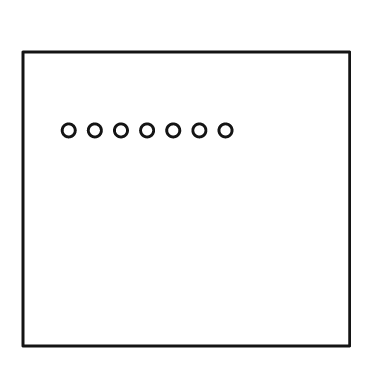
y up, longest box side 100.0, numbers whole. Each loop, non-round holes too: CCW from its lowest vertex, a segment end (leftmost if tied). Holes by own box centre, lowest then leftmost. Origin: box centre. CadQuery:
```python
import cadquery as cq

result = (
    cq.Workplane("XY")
    .moveTo(-50.0, -45.0)
    .lineTo(50.0, -45.0)
    .lineTo(50.0, 45.0)
    .lineTo(-50.0, 45.0)
    .close()
    .moveTo(-36.0, 21.0)
    .circle(2.0)
    .moveTo(-28.0, 21.0)
    .circle(2.0)
    .moveTo(-20.0, 21.0)
    .circle(2.0)
    .moveTo(-12.0, 21.0)
    .circle(2.0)
    .moveTo(-4.0, 21.0)
    .circle(2.0)
    .moveTo(4.0, 21.0)
    .circle(2.0)
    .moveTo(12.0, 21.0)
    .circle(2.0)
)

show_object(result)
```